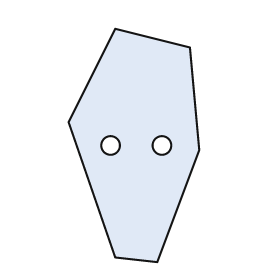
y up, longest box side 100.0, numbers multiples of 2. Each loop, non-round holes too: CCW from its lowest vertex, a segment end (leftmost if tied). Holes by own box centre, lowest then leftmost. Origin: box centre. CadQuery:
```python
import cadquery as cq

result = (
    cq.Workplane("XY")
    .moveTo(10.0, -50.0)
    .lineTo(28.0, -2.0)
    .lineTo(24.0, 42.0)
    .lineTo(-8.0, 50.0)
    .lineTo(-28.0, 10.0)
    .lineTo(-8.0, -48.0)
    .close()
    .moveTo(-10.0, 0.0)
    .circle(4.0)
    .moveTo(12.0, 0.0)
    .circle(4.0)
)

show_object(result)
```